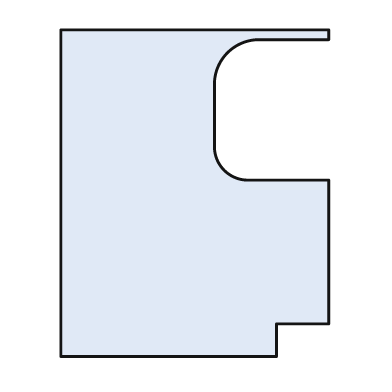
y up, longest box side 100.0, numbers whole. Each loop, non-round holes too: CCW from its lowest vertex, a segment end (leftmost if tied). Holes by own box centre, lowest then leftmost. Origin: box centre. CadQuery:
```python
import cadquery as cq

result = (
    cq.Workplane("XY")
    .moveTo(-41.0, -50.0)
    .lineTo(25.0, -50.0)
    .lineTo(25.0, -40.0)
    .lineTo(41.0, -40.0)
    .lineTo(41.0, 4.0)
    .lineTo(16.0, 4.0)
    .threePointArc((9.0, 7.0), (6.0, 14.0))
    .lineTo(6.0, 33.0)
    .threePointArc((10.0, 43.0), (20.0, 47.0))
    .lineTo(41.0, 47.0)
    .lineTo(41.0, 50.0)
    .lineTo(-41.0, 50.0)
    .close()
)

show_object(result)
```